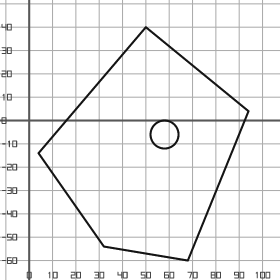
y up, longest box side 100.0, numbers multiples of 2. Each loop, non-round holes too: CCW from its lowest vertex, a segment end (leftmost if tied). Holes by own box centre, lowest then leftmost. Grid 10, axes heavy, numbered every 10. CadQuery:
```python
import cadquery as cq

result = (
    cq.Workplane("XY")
    .moveTo(68.0, -60.0)
    .lineTo(94.0, 4.0)
    .lineTo(50.0, 40.0)
    .lineTo(4.0, -14.0)
    .lineTo(32.0, -54.0)
    .close()
    .moveTo(58.0, -6.0)
    .circle(6.0)
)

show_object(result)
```